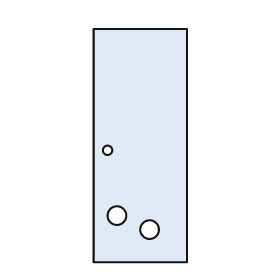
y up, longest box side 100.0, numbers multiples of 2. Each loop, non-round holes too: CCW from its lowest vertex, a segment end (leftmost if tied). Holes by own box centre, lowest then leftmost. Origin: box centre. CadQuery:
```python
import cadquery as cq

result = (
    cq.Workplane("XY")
    .moveTo(-20.0, -50.0)
    .lineTo(20.0, -50.0)
    .lineTo(20.0, 50.0)
    .lineTo(-20.0, 50.0)
    .close()
    .moveTo(4.0, -36.0)
    .circle(4.0)
    .moveTo(-10.0, -30.0)
    .circle(4.0)
    .moveTo(-14.0, -2.0)
    .circle(2.0)
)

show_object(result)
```